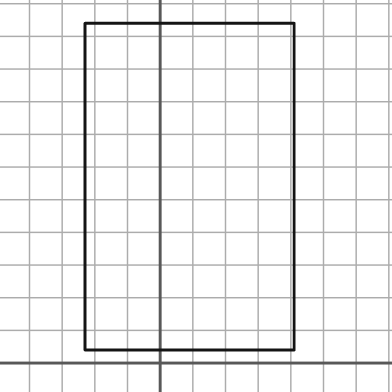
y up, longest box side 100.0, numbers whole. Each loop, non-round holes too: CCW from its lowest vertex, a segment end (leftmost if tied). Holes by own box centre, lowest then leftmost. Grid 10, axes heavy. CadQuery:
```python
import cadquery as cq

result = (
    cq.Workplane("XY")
    .moveTo(-23.0, 4.0)
    .lineTo(41.0, 4.0)
    .lineTo(41.0, 104.0)
    .lineTo(-23.0, 104.0)
    .close()
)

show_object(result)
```